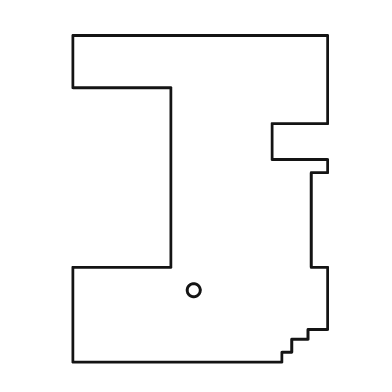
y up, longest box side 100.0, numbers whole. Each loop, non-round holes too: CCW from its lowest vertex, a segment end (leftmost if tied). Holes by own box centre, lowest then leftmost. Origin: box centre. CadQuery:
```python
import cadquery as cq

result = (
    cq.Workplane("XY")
    .moveTo(-39.0, -50.0)
    .lineTo(25.0, -50.0)
    .lineTo(25.0, -47.0)
    .lineTo(28.0, -47.0)
    .lineTo(28.0, -43.0)
    .lineTo(33.0, -43.0)
    .lineTo(33.0, -40.0)
    .lineTo(39.0, -40.0)
    .lineTo(39.0, -21.0)
    .lineTo(34.0, -21.0)
    .lineTo(34.0, 8.0)
    .lineTo(39.0, 8.0)
    .lineTo(39.0, 12.0)
    .lineTo(22.0, 12.0)
    .lineTo(22.0, 23.0)
    .lineTo(39.0, 23.0)
    .lineTo(39.0, 50.0)
    .lineTo(-39.0, 50.0)
    .lineTo(-39.0, 34.0)
    .lineTo(-9.0, 34.0)
    .lineTo(-9.0, -21.0)
    .lineTo(-39.0, -21.0)
    .close()
    .moveTo(-2.0, -28.0)
    .circle(2.0)
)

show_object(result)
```